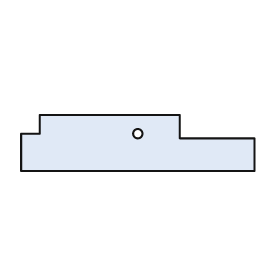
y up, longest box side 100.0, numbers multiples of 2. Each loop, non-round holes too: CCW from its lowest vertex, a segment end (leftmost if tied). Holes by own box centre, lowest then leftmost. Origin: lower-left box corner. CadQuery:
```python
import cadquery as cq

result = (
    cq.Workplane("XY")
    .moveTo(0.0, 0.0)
    .lineTo(100.0, 0.0)
    .lineTo(100.0, 14.0)
    .lineTo(68.0, 14.0)
    .lineTo(68.0, 24.0)
    .lineTo(8.0, 24.0)
    .lineTo(8.0, 16.0)
    .lineTo(0.0, 16.0)
    .close()
    .moveTo(50.0, 16.0)
    .circle(2.0)
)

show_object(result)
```